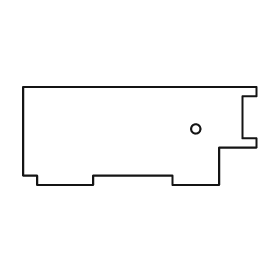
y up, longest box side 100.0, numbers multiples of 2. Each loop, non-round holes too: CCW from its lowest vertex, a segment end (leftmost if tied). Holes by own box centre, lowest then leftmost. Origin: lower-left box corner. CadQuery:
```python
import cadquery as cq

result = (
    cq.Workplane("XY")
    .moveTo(6.0, 0.0)
    .lineTo(30.0, 0.0)
    .lineTo(30.0, 4.0)
    .lineTo(64.0, 4.0)
    .lineTo(64.0, 0.0)
    .lineTo(84.0, 0.0)
    .lineTo(84.0, 16.0)
    .lineTo(100.0, 16.0)
    .lineTo(100.0, 20.0)
    .lineTo(94.0, 20.0)
    .lineTo(94.0, 38.0)
    .lineTo(100.0, 38.0)
    .lineTo(100.0, 42.0)
    .lineTo(0.0, 42.0)
    .lineTo(0.0, 4.0)
    .lineTo(6.0, 4.0)
    .close()
    .moveTo(74.0, 24.0)
    .circle(2.0)
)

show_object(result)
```